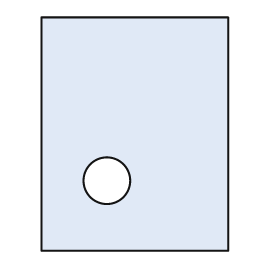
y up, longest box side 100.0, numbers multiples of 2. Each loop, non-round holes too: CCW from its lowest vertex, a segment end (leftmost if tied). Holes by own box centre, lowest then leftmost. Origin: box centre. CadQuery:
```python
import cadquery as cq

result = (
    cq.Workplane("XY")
    .moveTo(-40.0, -50.0)
    .lineTo(40.0, -50.0)
    .lineTo(40.0, 50.0)
    .lineTo(-40.0, 50.0)
    .close()
    .moveTo(-12.0, -20.0)
    .circle(10.0)
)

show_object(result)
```